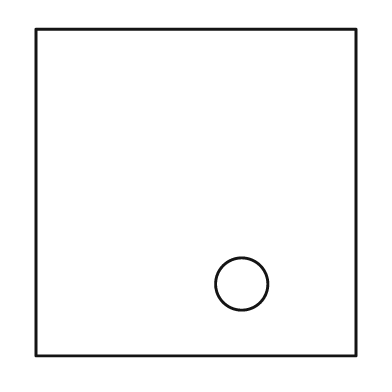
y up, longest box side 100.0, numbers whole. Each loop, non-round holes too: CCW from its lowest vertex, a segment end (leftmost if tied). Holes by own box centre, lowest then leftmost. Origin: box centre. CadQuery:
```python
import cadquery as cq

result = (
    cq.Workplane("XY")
    .moveTo(-49.0, -50.0)
    .lineTo(49.0, -50.0)
    .lineTo(49.0, 50.0)
    .lineTo(-49.0, 50.0)
    .close()
    .moveTo(14.0, -28.0)
    .circle(8.0)
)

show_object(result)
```